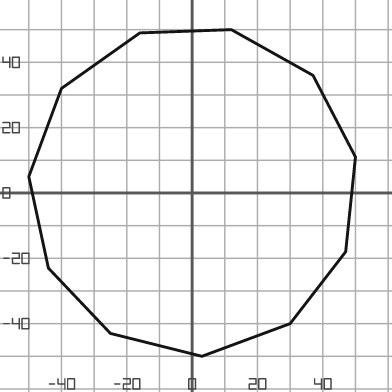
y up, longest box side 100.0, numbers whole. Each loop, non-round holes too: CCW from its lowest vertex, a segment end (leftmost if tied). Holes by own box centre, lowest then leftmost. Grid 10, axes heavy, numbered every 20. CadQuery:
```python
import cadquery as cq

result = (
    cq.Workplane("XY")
    .moveTo(3.0, -50.0)
    .lineTo(30.0, -40.0)
    .lineTo(47.0, -18.0)
    .lineTo(50.0, 11.0)
    .lineTo(37.0, 36.0)
    .lineTo(12.0, 50.0)
    .lineTo(-16.0, 49.0)
    .lineTo(-40.0, 32.0)
    .lineTo(-50.0, 5.0)
    .lineTo(-44.0, -23.0)
    .lineTo(-25.0, -43.0)
    .close()
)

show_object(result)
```